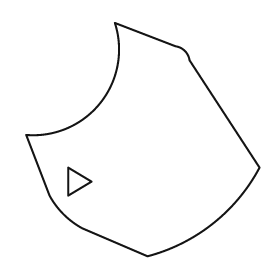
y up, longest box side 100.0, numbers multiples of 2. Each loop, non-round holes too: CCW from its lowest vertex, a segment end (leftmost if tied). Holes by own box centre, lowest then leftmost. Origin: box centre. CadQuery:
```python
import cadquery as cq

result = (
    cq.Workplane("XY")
    .moveTo(2.0, -50.0)
    .threePointArc((30.0, -36.0), (50.0, -12.0))
    .lineTo(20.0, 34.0)
    .threePointArc((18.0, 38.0), (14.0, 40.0))
    .lineTo(-12.0, 50.0)
    .threePointArc((-18.0, 16.0), (-50.0, 2.0))
    .lineTo(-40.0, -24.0)
    .threePointArc((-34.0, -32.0), (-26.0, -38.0))
    .close()
    .moveTo(-32.0, -24.0)
    .lineTo(-22.0, -18.0)
    .lineTo(-32.0, -12.0)
    .close()
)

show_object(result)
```